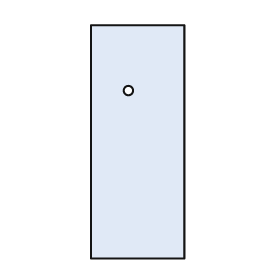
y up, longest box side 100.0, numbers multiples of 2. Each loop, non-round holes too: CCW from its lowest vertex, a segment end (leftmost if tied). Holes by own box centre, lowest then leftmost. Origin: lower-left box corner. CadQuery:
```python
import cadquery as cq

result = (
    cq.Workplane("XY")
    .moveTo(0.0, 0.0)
    .lineTo(40.0, 0.0)
    .lineTo(40.0, 100.0)
    .lineTo(0.0, 100.0)
    .close()
    .moveTo(16.0, 72.0)
    .circle(2.0)
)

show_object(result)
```